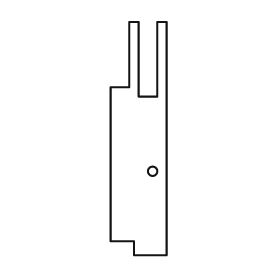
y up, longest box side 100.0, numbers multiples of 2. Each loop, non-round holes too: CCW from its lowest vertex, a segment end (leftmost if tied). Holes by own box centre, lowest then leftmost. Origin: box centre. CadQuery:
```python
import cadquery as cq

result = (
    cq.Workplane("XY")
    .moveTo(-2.0, -50.0)
    .lineTo(12.0, -50.0)
    .lineTo(12.0, 50.0)
    .lineTo(8.0, 50.0)
    .lineTo(8.0, 18.0)
    .lineTo(0.0, 18.0)
    .lineTo(0.0, 50.0)
    .lineTo(-4.0, 50.0)
    .lineTo(-4.0, 22.0)
    .lineTo(-12.0, 22.0)
    .lineTo(-12.0, -44.0)
    .lineTo(-2.0, -44.0)
    .close()
    .moveTo(6.0, -14.0)
    .circle(2.0)
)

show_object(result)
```